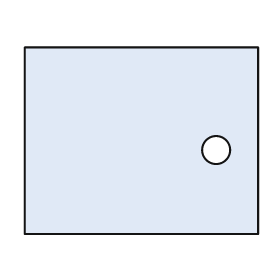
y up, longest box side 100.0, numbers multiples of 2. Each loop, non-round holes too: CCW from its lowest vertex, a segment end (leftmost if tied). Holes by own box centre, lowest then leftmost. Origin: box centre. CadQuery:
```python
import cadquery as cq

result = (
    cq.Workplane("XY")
    .moveTo(-50.0, -40.0)
    .lineTo(50.0, -40.0)
    .lineTo(50.0, 40.0)
    .lineTo(-50.0, 40.0)
    .close()
    .moveTo(32.0, -4.0)
    .circle(6.0)
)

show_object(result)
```